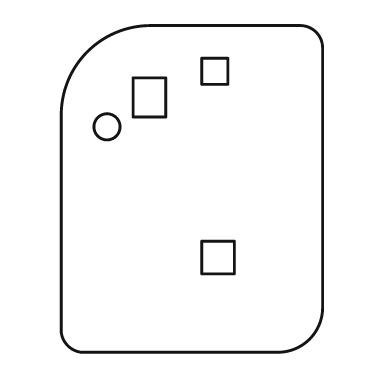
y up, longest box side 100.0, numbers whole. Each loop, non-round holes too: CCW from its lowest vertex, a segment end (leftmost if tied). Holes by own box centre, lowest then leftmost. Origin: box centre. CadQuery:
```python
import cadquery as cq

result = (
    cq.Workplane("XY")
    .moveTo(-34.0, -50.0)
    .lineTo(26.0, -50.0)
    .threePointArc((36.0, -46.0), (40.0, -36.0))
    .lineTo(40.0, 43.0)
    .threePointArc((38.0, 48.0), (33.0, 50.0))
    .lineTo(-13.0, 50.0)
    .threePointArc((-32.0, 42.0), (-40.0, 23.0))
    .lineTo(-40.0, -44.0)
    .threePointArc((-38.0, -48.0), (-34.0, -50.0))
    .close()
    .moveTo(3.0, -26.0)
    .lineTo(13.0, -26.0)
    .lineTo(13.0, -16.0)
    .lineTo(3.0, -16.0)
    .close()
    .moveTo(-26.0, 19.0)
    .circle(4.0)
    .moveTo(-18.0, 22.0)
    .lineTo(-8.0, 22.0)
    .lineTo(-8.0, 34.0)
    .lineTo(-18.0, 34.0)
    .close()
    .moveTo(3.0, 32.0)
    .lineTo(11.0, 32.0)
    .lineTo(11.0, 40.0)
    .lineTo(3.0, 40.0)
    .close()
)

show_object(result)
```